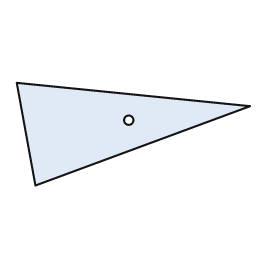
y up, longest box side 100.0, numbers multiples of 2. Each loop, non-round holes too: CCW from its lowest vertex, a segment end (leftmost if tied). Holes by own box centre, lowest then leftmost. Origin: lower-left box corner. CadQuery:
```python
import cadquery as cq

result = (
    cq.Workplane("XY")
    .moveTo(8.0, 0.0)
    .lineTo(100.0, 34.0)
    .lineTo(0.0, 44.0)
    .close()
    .moveTo(48.0, 28.0)
    .circle(2.0)
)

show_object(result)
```